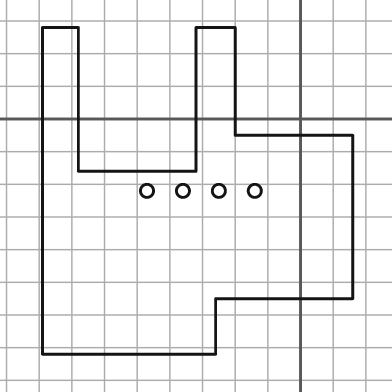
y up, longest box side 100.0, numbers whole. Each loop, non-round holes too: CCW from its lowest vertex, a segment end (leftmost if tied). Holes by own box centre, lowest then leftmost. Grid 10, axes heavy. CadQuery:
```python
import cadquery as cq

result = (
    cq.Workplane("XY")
    .moveTo(-79.0, -72.0)
    .lineTo(-26.0, -72.0)
    .lineTo(-26.0, -55.0)
    .lineTo(16.0, -55.0)
    .lineTo(16.0, -5.0)
    .lineTo(-20.0, -5.0)
    .lineTo(-20.0, 28.0)
    .lineTo(-32.0, 28.0)
    .lineTo(-32.0, -16.0)
    .lineTo(-68.0, -16.0)
    .lineTo(-68.0, 28.0)
    .lineTo(-79.0, 28.0)
    .close()
    .moveTo(-47.0, -22.0)
    .circle(2.0)
    .moveTo(-36.0, -22.0)
    .circle(2.0)
    .moveTo(-25.0, -22.0)
    .circle(2.0)
    .moveTo(-14.0, -22.0)
    .circle(2.0)
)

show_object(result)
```